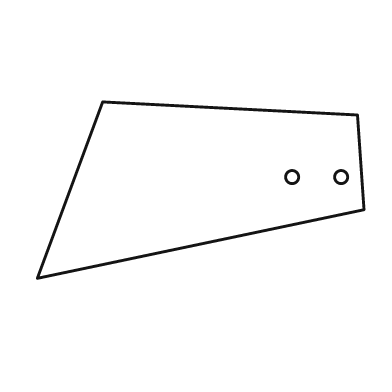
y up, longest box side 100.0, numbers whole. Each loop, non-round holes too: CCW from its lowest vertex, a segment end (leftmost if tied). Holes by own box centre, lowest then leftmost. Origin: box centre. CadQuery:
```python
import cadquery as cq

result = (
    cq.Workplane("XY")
    .moveTo(-50.0, -27.0)
    .lineTo(50.0, -6.0)
    .lineTo(48.0, 23.0)
    .lineTo(-30.0, 27.0)
    .close()
    .moveTo(28.0, 4.0)
    .circle(2.0)
    .moveTo(43.0, 4.0)
    .circle(2.0)
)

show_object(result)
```